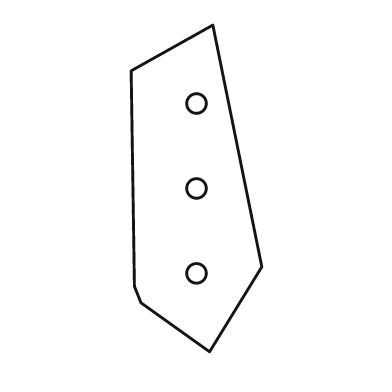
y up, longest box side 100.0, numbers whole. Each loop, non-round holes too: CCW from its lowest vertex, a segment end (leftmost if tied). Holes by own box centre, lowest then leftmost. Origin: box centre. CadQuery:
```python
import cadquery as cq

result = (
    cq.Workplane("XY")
    .moveTo(4.0, -50.0)
    .lineTo(20.0, -24.0)
    .lineTo(5.0, 50.0)
    .lineTo(-20.0, 36.0)
    .lineTo(-19.0, -30.0)
    .lineTo(-17.0, -35.0)
    .close()
    .moveTo(0.0, -26.0)
    .circle(3.0)
    .moveTo(0.0, 0.0)
    .circle(3.0)
    .moveTo(0.0, 26.0)
    .circle(3.0)
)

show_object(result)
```